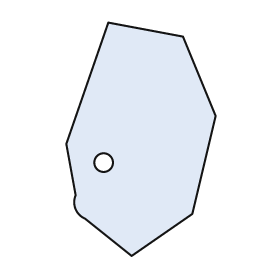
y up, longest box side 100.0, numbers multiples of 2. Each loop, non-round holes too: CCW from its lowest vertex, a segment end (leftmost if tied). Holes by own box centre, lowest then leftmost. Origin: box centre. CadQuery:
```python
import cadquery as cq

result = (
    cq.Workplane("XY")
    .moveTo(-4.0, -50.0)
    .lineTo(22.0, -32.0)
    .lineTo(32.0, 10.0)
    .lineTo(18.0, 44.0)
    .lineTo(-14.0, 50.0)
    .lineTo(-32.0, -2.0)
    .lineTo(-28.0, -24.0)
    .threePointArc((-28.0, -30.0), (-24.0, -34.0))
    .close()
    .moveTo(-16.0, -10.0)
    .circle(4.0)
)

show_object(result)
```